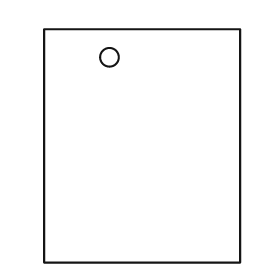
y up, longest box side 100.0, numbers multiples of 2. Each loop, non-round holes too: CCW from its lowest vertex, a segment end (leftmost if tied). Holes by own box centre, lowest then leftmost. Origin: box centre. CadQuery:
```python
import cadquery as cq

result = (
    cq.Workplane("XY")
    .moveTo(-42.0, -50.0)
    .lineTo(42.0, -50.0)
    .lineTo(42.0, 50.0)
    .lineTo(-42.0, 50.0)
    .close()
    .moveTo(-14.0, 38.0)
    .circle(4.0)
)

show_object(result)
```